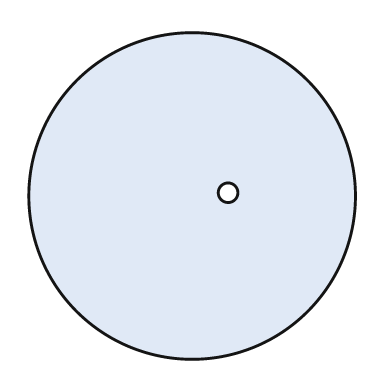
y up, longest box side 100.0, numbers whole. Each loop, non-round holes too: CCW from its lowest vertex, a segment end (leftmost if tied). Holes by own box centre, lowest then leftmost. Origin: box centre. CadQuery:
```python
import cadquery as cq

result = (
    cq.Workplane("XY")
    .moveTo(0.0, 0.0)
    .circle(50.0)
    .moveTo(11.0, 1.0)
    .circle(3.0)
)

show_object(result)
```